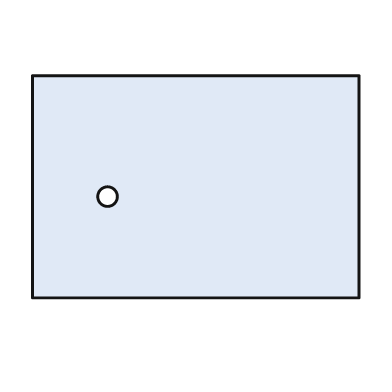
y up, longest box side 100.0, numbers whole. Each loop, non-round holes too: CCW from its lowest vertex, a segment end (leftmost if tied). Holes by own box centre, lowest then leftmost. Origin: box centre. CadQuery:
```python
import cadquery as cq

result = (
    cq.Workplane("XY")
    .moveTo(-50.0, -34.0)
    .lineTo(50.0, -34.0)
    .lineTo(50.0, 34.0)
    .lineTo(-50.0, 34.0)
    .close()
    .moveTo(-27.0, -3.0)
    .circle(3.0)
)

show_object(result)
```